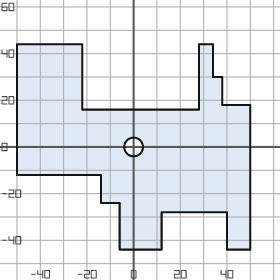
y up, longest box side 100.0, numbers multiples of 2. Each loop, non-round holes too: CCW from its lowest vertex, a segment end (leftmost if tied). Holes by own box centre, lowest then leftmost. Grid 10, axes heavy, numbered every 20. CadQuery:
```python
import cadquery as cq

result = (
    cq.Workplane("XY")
    .moveTo(-6.0, -44.0)
    .lineTo(12.0, -44.0)
    .lineTo(12.0, -28.0)
    .lineTo(40.0, -28.0)
    .lineTo(40.0, -44.0)
    .lineTo(50.0, -44.0)
    .lineTo(50.0, 18.0)
    .lineTo(38.0, 18.0)
    .lineTo(38.0, 30.0)
    .lineTo(34.0, 30.0)
    .lineTo(34.0, 44.0)
    .lineTo(28.0, 44.0)
    .lineTo(28.0, 16.0)
    .lineTo(-22.0, 16.0)
    .lineTo(-22.0, 44.0)
    .lineTo(-50.0, 44.0)
    .lineTo(-50.0, -12.0)
    .lineTo(-14.0, -12.0)
    .lineTo(-14.0, -24.0)
    .lineTo(-6.0, -24.0)
    .close()
    .moveTo(0.0, 0.0)
    .circle(4.0)
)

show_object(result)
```